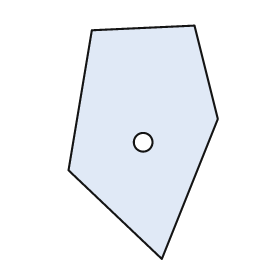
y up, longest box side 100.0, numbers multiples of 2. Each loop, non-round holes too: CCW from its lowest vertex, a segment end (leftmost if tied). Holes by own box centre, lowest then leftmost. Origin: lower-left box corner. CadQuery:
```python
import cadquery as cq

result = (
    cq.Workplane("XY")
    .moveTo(40.0, 0.0)
    .lineTo(64.0, 60.0)
    .lineTo(54.0, 100.0)
    .lineTo(10.0, 98.0)
    .lineTo(0.0, 38.0)
    .close()
    .moveTo(32.0, 50.0)
    .circle(4.0)
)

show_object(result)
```